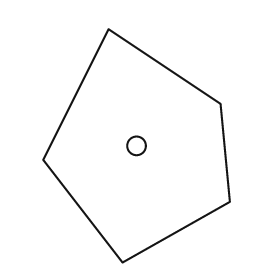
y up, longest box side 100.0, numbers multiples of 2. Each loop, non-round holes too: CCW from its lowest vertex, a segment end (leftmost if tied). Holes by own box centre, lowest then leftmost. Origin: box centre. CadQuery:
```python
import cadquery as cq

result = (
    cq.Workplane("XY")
    .moveTo(-6.0, -50.0)
    .lineTo(40.0, -24.0)
    .lineTo(36.0, 18.0)
    .lineTo(-12.0, 50.0)
    .lineTo(-40.0, -6.0)
    .close()
    .moveTo(0.0, 0.0)
    .circle(4.0)
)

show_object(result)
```